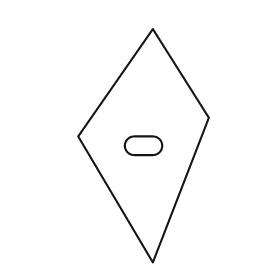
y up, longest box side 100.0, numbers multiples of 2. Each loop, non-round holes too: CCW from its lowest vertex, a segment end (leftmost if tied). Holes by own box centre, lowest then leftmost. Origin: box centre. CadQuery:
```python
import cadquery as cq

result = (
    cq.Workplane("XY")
    .moveTo(4.0, -50.0)
    .lineTo(28.0, 12.0)
    .lineTo(4.0, 50.0)
    .lineTo(-28.0, 4.0)
    .close()
    .moveTo(-4.0, -4.0)
    .lineTo(4.0, -4.0)
    .threePointArc((8.0, 0.0), (4.0, 4.0))
    .lineTo(-4.0, 4.0)
    .threePointArc((-8.0, 0.0), (-4.0, -4.0))
    .close()
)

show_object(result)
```